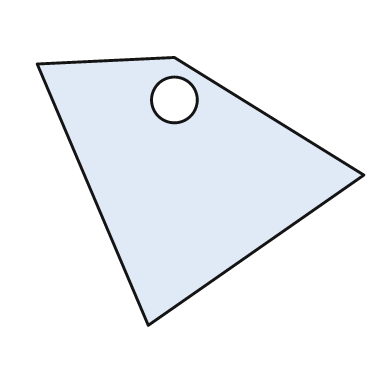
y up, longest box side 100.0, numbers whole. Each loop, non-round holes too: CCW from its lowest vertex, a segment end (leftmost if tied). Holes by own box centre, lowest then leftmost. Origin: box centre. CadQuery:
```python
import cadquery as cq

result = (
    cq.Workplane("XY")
    .moveTo(-16.0, -41.0)
    .lineTo(50.0, 5.0)
    .lineTo(-8.0, 41.0)
    .lineTo(-50.0, 39.0)
    .close()
    .moveTo(-8.0, 28.0)
    .circle(7.0)
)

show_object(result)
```